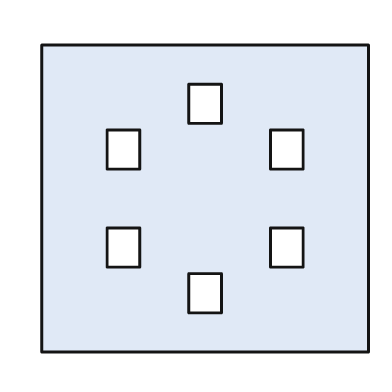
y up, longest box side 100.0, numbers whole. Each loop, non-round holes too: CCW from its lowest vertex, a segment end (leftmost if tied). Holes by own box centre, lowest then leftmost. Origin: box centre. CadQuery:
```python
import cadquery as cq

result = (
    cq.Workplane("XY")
    .moveTo(-50.0, -47.0)
    .lineTo(50.0, -47.0)
    .lineTo(50.0, 47.0)
    .lineTo(-50.0, 47.0)
    .close()
    .moveTo(-5.0, -35.0)
    .lineTo(5.0, -35.0)
    .lineTo(5.0, -23.0)
    .lineTo(-5.0, -23.0)
    .close()
    .moveTo(-30.0, -21.0)
    .lineTo(-20.0, -21.0)
    .lineTo(-20.0, -9.0)
    .lineTo(-30.0, -9.0)
    .close()
    .moveTo(20.0, -21.0)
    .lineTo(30.0, -21.0)
    .lineTo(30.0, -9.0)
    .lineTo(20.0, -9.0)
    .close()
    .moveTo(-30.0, 9.0)
    .lineTo(-20.0, 9.0)
    .lineTo(-20.0, 21.0)
    .lineTo(-30.0, 21.0)
    .close()
    .moveTo(20.0, 9.0)
    .lineTo(30.0, 9.0)
    .lineTo(30.0, 21.0)
    .lineTo(20.0, 21.0)
    .close()
    .moveTo(-5.0, 23.0)
    .lineTo(5.0, 23.0)
    .lineTo(5.0, 35.0)
    .lineTo(-5.0, 35.0)
    .close()
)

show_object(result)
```